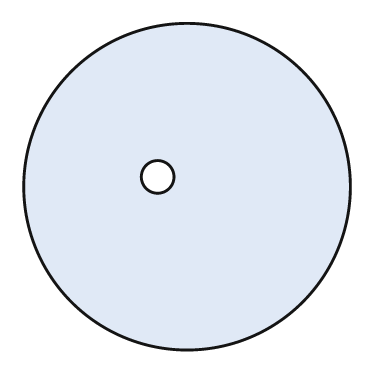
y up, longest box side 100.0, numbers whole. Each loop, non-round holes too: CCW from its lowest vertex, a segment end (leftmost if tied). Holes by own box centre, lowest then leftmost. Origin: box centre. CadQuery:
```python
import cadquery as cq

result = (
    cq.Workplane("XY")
    .moveTo(0.0, 0.0)
    .circle(50.0)
    .moveTo(-9.0, 3.0)
    .circle(5.0)
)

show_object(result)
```